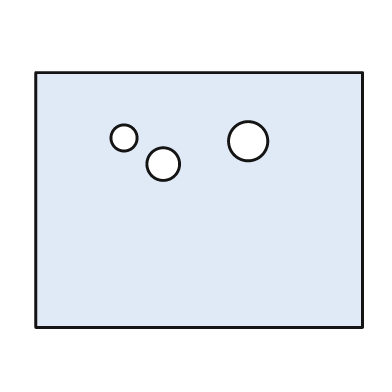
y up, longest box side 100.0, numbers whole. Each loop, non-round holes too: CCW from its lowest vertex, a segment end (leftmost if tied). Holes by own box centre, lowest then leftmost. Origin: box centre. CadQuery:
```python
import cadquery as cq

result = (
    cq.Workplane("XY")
    .moveTo(-50.0, -39.0)
    .lineTo(50.0, -39.0)
    .lineTo(50.0, 39.0)
    .lineTo(-50.0, 39.0)
    .close()
    .moveTo(-11.0, 11.0)
    .circle(5.0)
    .moveTo(15.0, 18.0)
    .circle(6.0)
    .moveTo(-23.0, 19.0)
    .circle(4.0)
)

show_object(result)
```